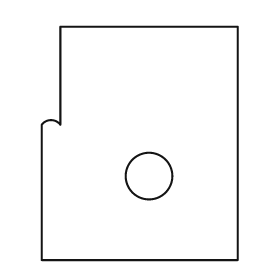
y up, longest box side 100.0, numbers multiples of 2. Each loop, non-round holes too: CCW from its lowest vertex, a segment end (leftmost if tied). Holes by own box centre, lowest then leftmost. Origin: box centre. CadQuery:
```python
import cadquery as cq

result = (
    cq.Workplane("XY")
    .moveTo(-42.0, -50.0)
    .lineTo(42.0, -50.0)
    .lineTo(42.0, 50.0)
    .lineTo(-34.0, 50.0)
    .lineTo(-34.0, 8.0)
    .threePointArc((-38.0, 10.0), (-42.0, 8.0))
    .close()
    .moveTo(4.0, -14.0)
    .circle(10.0)
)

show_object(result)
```